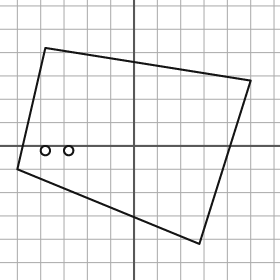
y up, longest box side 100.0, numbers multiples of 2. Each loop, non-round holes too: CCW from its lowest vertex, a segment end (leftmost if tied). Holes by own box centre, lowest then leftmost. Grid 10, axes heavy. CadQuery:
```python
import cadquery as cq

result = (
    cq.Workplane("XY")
    .moveTo(28.0, -42.0)
    .lineTo(50.0, 28.0)
    .lineTo(-38.0, 42.0)
    .lineTo(-50.0, -10.0)
    .close()
    .moveTo(-38.0, -2.0)
    .circle(2.0)
    .moveTo(-28.0, -2.0)
    .circle(2.0)
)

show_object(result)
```